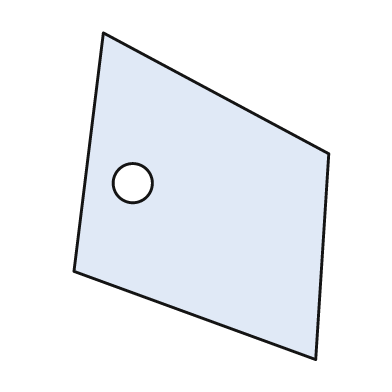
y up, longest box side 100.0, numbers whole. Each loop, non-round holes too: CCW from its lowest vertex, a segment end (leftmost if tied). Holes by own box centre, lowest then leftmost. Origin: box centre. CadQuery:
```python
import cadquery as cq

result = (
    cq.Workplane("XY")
    .moveTo(35.0, -50.0)
    .lineTo(39.0, 13.0)
    .lineTo(-30.0, 50.0)
    .lineTo(-39.0, -23.0)
    .close()
    .moveTo(-21.0, 4.0)
    .circle(6.0)
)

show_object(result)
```